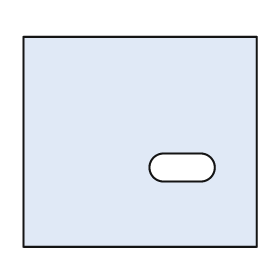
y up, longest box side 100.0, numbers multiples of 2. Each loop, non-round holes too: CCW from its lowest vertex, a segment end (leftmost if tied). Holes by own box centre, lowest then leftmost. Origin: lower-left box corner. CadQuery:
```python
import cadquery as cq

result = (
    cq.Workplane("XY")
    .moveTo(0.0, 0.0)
    .lineTo(100.0, 0.0)
    .lineTo(100.0, 90.0)
    .lineTo(0.0, 90.0)
    .close()
    .moveTo(60.0, 28.0)
    .lineTo(76.0, 28.0)
    .threePointArc((82.0, 34.0), (76.0, 40.0))
    .lineTo(60.0, 40.0)
    .threePointArc((54.0, 34.0), (60.0, 28.0))
    .close()
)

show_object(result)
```